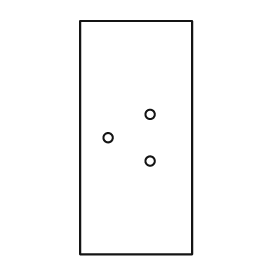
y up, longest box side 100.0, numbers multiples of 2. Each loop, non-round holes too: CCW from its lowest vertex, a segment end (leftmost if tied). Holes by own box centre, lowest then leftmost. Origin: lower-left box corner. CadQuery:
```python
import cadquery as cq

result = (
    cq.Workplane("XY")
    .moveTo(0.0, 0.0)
    .lineTo(48.0, 0.0)
    .lineTo(48.0, 100.0)
    .lineTo(0.0, 100.0)
    .close()
    .moveTo(30.0, 40.0)
    .circle(2.0)
    .moveTo(12.0, 50.0)
    .circle(2.0)
    .moveTo(30.0, 60.0)
    .circle(2.0)
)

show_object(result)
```